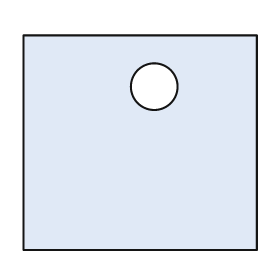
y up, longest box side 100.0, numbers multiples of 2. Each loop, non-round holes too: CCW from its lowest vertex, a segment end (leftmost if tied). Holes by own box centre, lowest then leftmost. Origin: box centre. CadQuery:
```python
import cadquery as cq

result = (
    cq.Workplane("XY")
    .moveTo(-50.0, -46.0)
    .lineTo(50.0, -46.0)
    .lineTo(50.0, 46.0)
    .lineTo(-50.0, 46.0)
    .close()
    .moveTo(6.0, 24.0)
    .circle(10.0)
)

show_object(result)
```